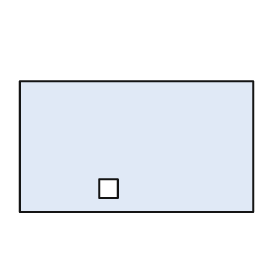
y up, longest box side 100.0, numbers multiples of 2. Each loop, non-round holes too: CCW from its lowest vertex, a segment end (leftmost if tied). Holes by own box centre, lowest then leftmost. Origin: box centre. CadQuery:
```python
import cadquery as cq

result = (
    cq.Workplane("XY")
    .moveTo(-50.0, -28.0)
    .lineTo(50.0, -28.0)
    .lineTo(50.0, 28.0)
    .lineTo(-50.0, 28.0)
    .close()
    .moveTo(-16.0, -22.0)
    .lineTo(-8.0, -22.0)
    .lineTo(-8.0, -14.0)
    .lineTo(-16.0, -14.0)
    .close()
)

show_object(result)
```